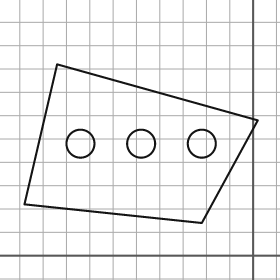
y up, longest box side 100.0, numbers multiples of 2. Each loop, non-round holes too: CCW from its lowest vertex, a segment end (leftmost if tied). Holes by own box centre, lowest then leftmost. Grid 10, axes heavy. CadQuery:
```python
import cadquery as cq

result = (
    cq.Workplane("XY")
    .moveTo(-22.0, 14.0)
    .lineTo(2.0, 58.0)
    .lineTo(-84.0, 82.0)
    .lineTo(-98.0, 22.0)
    .close()
    .moveTo(-74.0, 48.0)
    .circle(6.0)
    .moveTo(-48.0, 48.0)
    .circle(6.0)
    .moveTo(-22.0, 48.0)
    .circle(6.0)
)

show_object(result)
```